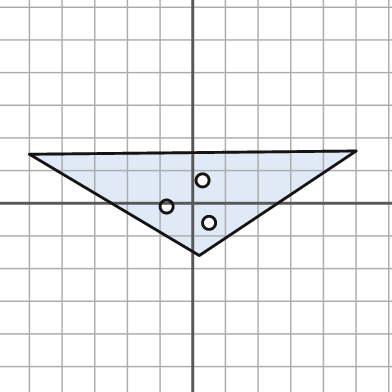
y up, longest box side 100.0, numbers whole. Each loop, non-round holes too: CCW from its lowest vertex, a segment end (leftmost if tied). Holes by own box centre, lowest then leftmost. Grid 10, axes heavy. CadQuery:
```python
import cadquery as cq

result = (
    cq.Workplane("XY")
    .moveTo(2.0, -16.0)
    .lineTo(50.0, 16.0)
    .lineTo(-50.0, 15.0)
    .close()
    .moveTo(5.0, -6.0)
    .circle(2.0)
    .moveTo(-8.0, -1.0)
    .circle(2.0)
    .moveTo(3.0, 7.0)
    .circle(2.0)
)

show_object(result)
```